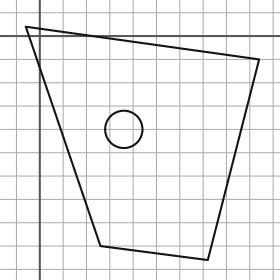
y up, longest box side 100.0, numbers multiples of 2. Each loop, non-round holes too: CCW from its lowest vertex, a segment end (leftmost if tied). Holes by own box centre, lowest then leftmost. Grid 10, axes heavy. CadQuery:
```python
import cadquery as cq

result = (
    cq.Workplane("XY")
    .moveTo(72.0, -96.0)
    .lineTo(94.0, -10.0)
    .lineTo(-6.0, 4.0)
    .lineTo(26.0, -90.0)
    .close()
    .moveTo(36.0, -40.0)
    .circle(8.0)
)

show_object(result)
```